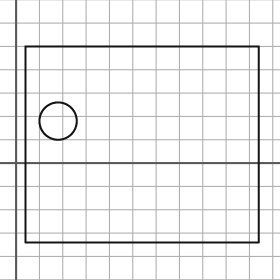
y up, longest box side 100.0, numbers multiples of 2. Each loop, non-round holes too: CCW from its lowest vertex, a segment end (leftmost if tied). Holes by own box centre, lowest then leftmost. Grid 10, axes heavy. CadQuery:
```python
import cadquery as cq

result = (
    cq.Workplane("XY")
    .moveTo(4.0, -34.0)
    .lineTo(104.0, -34.0)
    .lineTo(104.0, 50.0)
    .lineTo(4.0, 50.0)
    .close()
    .moveTo(18.0, 18.0)
    .circle(8.0)
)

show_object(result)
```